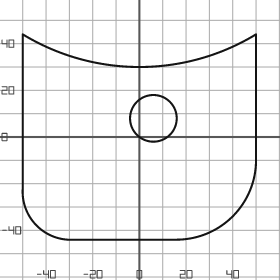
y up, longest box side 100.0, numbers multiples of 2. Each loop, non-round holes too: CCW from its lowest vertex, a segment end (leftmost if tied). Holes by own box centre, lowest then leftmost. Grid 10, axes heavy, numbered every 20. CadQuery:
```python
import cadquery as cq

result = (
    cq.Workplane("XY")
    .moveTo(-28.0, -44.0)
    .lineTo(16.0, -44.0)
    .threePointArc((40.0, -34.0), (50.0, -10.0))
    .lineTo(50.0, 44.0)
    .threePointArc((0.0, 30.0), (-50.0, 44.0))
    .lineTo(-50.0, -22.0)
    .threePointArc((-44.0, -38.0), (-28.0, -44.0))
    .close()
    .moveTo(6.0, 8.0)
    .circle(10.0)
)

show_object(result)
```